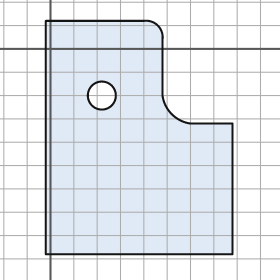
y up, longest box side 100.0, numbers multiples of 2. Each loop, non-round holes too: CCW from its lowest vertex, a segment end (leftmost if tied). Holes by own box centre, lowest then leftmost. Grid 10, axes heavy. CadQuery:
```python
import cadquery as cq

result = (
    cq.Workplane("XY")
    .moveTo(-2.0, -88.0)
    .lineTo(78.0, -88.0)
    .lineTo(78.0, -32.0)
    .lineTo(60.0, -32.0)
    .threePointArc((52.0, -28.0), (48.0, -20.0))
    .lineTo(48.0, 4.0)
    .threePointArc((46.0, 10.0), (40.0, 12.0))
    .lineTo(-2.0, 12.0)
    .close()
    .moveTo(22.0, -20.0)
    .circle(6.0)
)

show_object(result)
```